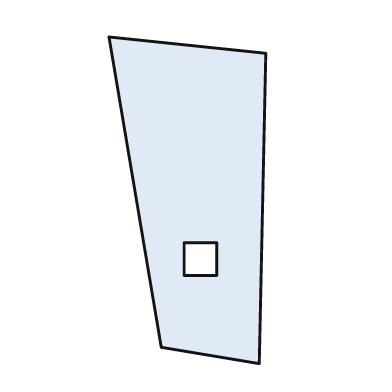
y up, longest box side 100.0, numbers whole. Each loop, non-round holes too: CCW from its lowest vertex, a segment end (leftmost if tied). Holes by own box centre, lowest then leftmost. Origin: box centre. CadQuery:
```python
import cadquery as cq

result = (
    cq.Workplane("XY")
    .moveTo(22.0, -50.0)
    .lineTo(24.0, 45.0)
    .lineTo(-24.0, 50.0)
    .lineTo(-8.0, -45.0)
    .close()
    .moveTo(-1.0, -23.0)
    .lineTo(9.0, -23.0)
    .lineTo(9.0, -13.0)
    .lineTo(-1.0, -13.0)
    .close()
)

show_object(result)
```